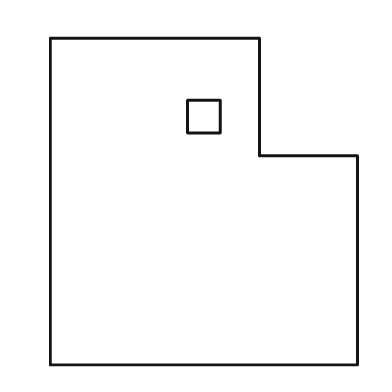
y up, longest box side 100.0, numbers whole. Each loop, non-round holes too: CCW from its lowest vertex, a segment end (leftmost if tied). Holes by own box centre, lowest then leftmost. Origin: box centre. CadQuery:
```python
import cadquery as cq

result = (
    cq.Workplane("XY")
    .moveTo(-47.0, -50.0)
    .lineTo(47.0, -50.0)
    .lineTo(47.0, 14.0)
    .lineTo(17.0, 14.0)
    .lineTo(17.0, 50.0)
    .lineTo(-47.0, 50.0)
    .close()
    .moveTo(-5.0, 21.0)
    .lineTo(5.0, 21.0)
    .lineTo(5.0, 31.0)
    .lineTo(-5.0, 31.0)
    .close()
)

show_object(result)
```